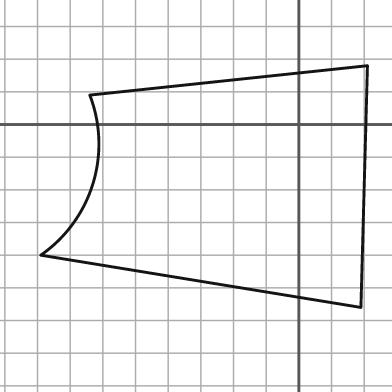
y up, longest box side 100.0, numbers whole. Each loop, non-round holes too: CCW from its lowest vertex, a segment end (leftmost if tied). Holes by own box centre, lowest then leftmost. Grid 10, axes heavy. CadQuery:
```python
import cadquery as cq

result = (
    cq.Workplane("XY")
    .moveTo(19.0, -56.0)
    .lineTo(21.0, 18.0)
    .lineTo(-64.0, 9.0)
    .threePointArc((-63.0, -18.0), (-79.0, -40.0))
    .close()
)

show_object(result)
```